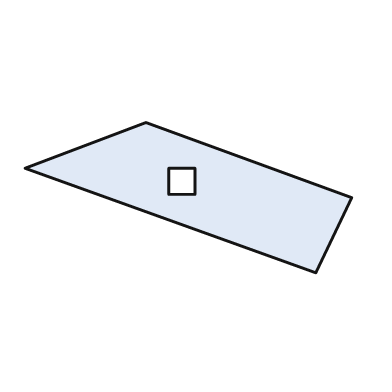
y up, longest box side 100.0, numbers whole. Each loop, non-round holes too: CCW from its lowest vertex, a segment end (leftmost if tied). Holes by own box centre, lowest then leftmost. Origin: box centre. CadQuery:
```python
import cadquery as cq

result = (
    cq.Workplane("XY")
    .moveTo(39.0, -23.0)
    .lineTo(50.0, 0.0)
    .lineTo(-13.0, 23.0)
    .lineTo(-50.0, 9.0)
    .close()
    .moveTo(-6.0, 1.0)
    .lineTo(2.0, 1.0)
    .lineTo(2.0, 9.0)
    .lineTo(-6.0, 9.0)
    .close()
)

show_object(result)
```